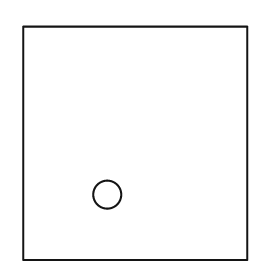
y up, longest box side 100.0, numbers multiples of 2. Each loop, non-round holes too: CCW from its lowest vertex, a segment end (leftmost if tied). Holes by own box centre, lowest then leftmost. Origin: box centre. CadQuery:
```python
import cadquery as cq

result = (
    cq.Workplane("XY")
    .moveTo(-48.0, -50.0)
    .lineTo(48.0, -50.0)
    .lineTo(48.0, 50.0)
    .lineTo(-48.0, 50.0)
    .close()
    .moveTo(-12.0, -22.0)
    .circle(6.0)
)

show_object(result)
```